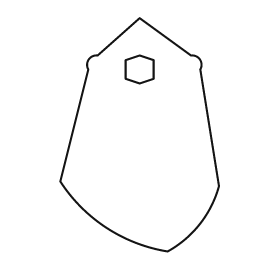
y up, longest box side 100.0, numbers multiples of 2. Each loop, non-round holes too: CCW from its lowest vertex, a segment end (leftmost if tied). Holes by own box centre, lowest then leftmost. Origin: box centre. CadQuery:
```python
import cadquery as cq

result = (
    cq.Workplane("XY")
    .moveTo(12.0, -50.0)
    .threePointArc((26.0, -38.0), (34.0, -22.0))
    .lineTo(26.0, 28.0)
    .threePointArc((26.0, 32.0), (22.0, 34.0))
    .lineTo(0.0, 50.0)
    .lineTo(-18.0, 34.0)
    .threePointArc((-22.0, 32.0), (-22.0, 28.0))
    .lineTo(-34.0, -20.0)
    .threePointArc((-14.0, -40.0), (12.0, -50.0))
    .close()
    .moveTo(0.0, 22.0)
    .lineTo(6.0, 24.0)
    .lineTo(6.0, 32.0)
    .lineTo(0.0, 34.0)
    .lineTo(-6.0, 32.0)
    .lineTo(-6.0, 24.0)
    .close()
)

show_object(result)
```